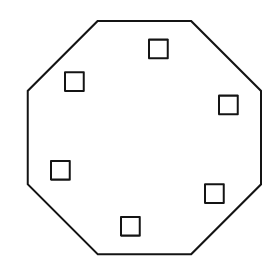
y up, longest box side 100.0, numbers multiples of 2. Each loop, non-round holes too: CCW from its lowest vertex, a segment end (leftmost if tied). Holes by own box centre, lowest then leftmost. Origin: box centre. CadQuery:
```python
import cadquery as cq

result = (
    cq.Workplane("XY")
    .moveTo(-20.0, -50.0)
    .lineTo(20.0, -50.0)
    .lineTo(50.0, -20.0)
    .lineTo(50.0, 20.0)
    .lineTo(20.0, 50.0)
    .lineTo(-20.0, 50.0)
    .lineTo(-50.0, 20.0)
    .lineTo(-50.0, -20.0)
    .close()
    .moveTo(-10.0, -42.0)
    .lineTo(-2.0, -42.0)
    .lineTo(-2.0, -34.0)
    .lineTo(-10.0, -34.0)
    .close()
    .moveTo(26.0, -28.0)
    .lineTo(34.0, -28.0)
    .lineTo(34.0, -20.0)
    .lineTo(26.0, -20.0)
    .close()
    .moveTo(-40.0, -18.0)
    .lineTo(-32.0, -18.0)
    .lineTo(-32.0, -10.0)
    .lineTo(-40.0, -10.0)
    .close()
    .moveTo(32.0, 10.0)
    .lineTo(40.0, 10.0)
    .lineTo(40.0, 18.0)
    .lineTo(32.0, 18.0)
    .close()
    .moveTo(-34.0, 20.0)
    .lineTo(-26.0, 20.0)
    .lineTo(-26.0, 28.0)
    .lineTo(-34.0, 28.0)
    .close()
    .moveTo(2.0, 34.0)
    .lineTo(10.0, 34.0)
    .lineTo(10.0, 42.0)
    .lineTo(2.0, 42.0)
    .close()
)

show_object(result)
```